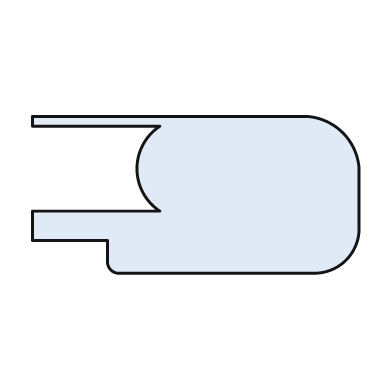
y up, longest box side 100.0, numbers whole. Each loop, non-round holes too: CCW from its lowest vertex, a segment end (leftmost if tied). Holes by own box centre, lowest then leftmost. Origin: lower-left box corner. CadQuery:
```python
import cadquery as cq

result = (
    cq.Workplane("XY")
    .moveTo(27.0, 0.0)
    .lineTo(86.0, 0.0)
    .threePointArc((96.0, 4.0), (100.0, 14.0))
    .lineTo(100.0, 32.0)
    .threePointArc((95.0, 43.0), (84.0, 48.0))
    .lineTo(0.0, 48.0)
    .lineTo(0.0, 45.0)
    .lineTo(39.0, 45.0)
    .threePointArc((32.0, 32.0), (39.0, 19.0))
    .lineTo(0.0, 19.0)
    .lineTo(0.0, 10.0)
    .lineTo(23.0, 10.0)
    .lineTo(23.0, 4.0)
    .threePointArc((24.0, 1.0), (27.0, 0.0))
    .close()
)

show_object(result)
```